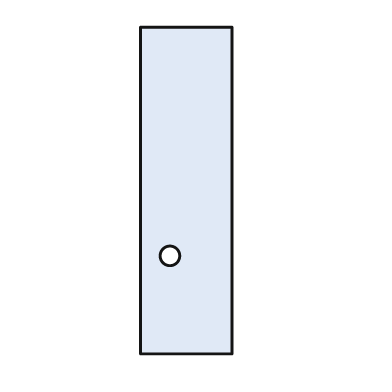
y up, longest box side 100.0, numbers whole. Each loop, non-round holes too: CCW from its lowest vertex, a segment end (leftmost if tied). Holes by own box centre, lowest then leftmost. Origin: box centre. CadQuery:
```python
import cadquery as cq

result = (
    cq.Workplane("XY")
    .moveTo(-14.0, -50.0)
    .lineTo(14.0, -50.0)
    .lineTo(14.0, 50.0)
    .lineTo(-14.0, 50.0)
    .close()
    .moveTo(-5.0, -20.0)
    .circle(3.0)
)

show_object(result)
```